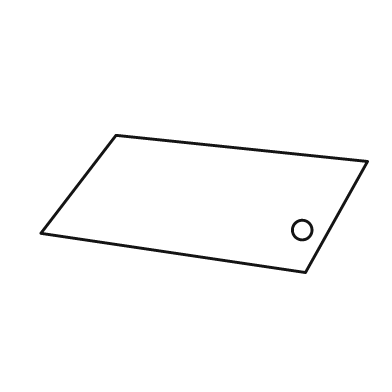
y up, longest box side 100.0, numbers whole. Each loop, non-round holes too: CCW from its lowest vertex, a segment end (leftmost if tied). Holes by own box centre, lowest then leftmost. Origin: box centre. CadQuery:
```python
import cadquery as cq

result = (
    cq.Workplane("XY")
    .moveTo(31.0, -21.0)
    .lineTo(50.0, 13.0)
    .lineTo(-27.0, 21.0)
    .lineTo(-50.0, -9.0)
    .close()
    .moveTo(30.0, -8.0)
    .circle(3.0)
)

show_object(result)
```